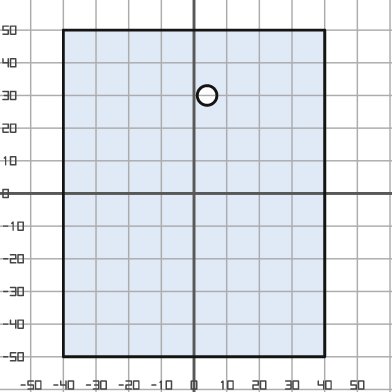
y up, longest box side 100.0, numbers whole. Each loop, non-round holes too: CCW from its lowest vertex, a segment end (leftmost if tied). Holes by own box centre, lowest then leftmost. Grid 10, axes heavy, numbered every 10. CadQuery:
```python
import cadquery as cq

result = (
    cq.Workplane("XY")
    .moveTo(-40.0, -50.0)
    .lineTo(40.0, -50.0)
    .lineTo(40.0, 50.0)
    .lineTo(-40.0, 50.0)
    .close()
    .moveTo(4.0, 30.0)
    .circle(3.0)
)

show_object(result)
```